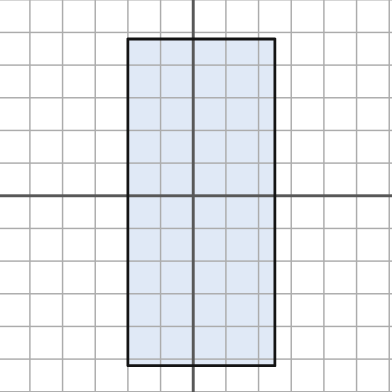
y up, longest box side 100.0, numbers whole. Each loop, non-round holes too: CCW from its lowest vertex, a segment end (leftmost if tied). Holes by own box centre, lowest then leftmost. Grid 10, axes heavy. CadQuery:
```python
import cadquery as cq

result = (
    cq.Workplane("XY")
    .moveTo(-20.0, -52.0)
    .lineTo(25.0, -52.0)
    .lineTo(25.0, 48.0)
    .lineTo(-20.0, 48.0)
    .close()
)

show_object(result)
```